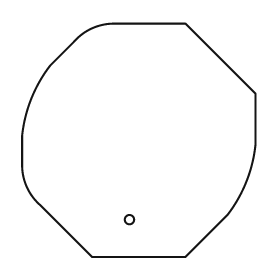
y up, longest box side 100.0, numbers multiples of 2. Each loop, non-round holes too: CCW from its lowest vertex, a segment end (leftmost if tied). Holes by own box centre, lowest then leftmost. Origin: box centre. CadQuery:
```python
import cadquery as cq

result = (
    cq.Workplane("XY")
    .moveTo(-20.0, -50.0)
    .lineTo(20.0, -50.0)
    .lineTo(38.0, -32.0)
    .threePointArc((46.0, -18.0), (50.0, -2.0))
    .lineTo(50.0, 20.0)
    .lineTo(20.0, 50.0)
    .lineTo(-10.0, 50.0)
    .threePointArc((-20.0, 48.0), (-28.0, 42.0))
    .lineTo(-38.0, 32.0)
    .threePointArc((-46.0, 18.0), (-50.0, 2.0))
    .lineTo(-50.0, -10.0)
    .threePointArc((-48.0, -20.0), (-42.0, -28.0))
    .close()
    .moveTo(-4.0, -34.0)
    .circle(2.0)
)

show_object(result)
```